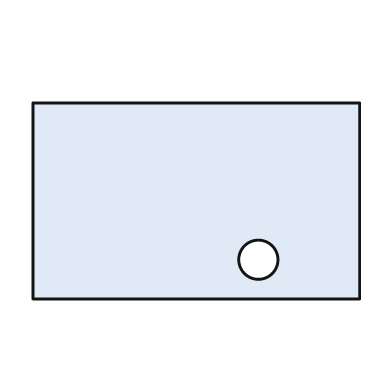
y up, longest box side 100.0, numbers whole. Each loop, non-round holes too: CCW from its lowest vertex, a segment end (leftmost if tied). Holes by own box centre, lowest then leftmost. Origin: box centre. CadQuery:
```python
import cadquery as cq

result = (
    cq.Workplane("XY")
    .moveTo(-50.0, -30.0)
    .lineTo(50.0, -30.0)
    .lineTo(50.0, 30.0)
    .lineTo(-50.0, 30.0)
    .close()
    .moveTo(19.0, -18.0)
    .circle(6.0)
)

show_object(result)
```